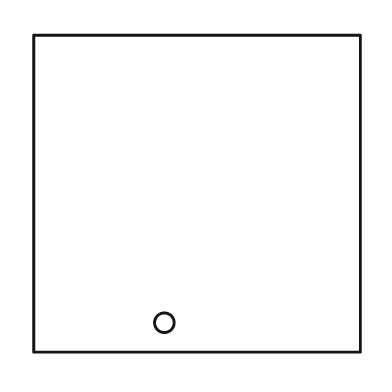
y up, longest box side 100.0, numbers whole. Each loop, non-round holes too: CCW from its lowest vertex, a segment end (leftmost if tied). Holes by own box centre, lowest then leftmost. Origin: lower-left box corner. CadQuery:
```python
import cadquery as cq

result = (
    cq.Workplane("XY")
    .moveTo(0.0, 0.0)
    .lineTo(100.0, 0.0)
    .lineTo(100.0, 97.0)
    .lineTo(0.0, 97.0)
    .close()
    .moveTo(40.0, 9.0)
    .circle(3.0)
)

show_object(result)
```